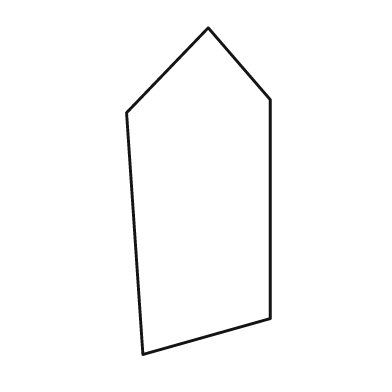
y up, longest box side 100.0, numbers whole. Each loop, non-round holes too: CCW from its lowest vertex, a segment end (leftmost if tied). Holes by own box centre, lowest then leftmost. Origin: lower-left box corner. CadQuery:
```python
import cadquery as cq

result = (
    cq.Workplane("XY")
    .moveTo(5.0, 0.0)
    .lineTo(44.0, 11.0)
    .lineTo(44.0, 78.0)
    .lineTo(25.0, 100.0)
    .lineTo(0.0, 74.0)
    .close()
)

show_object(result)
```